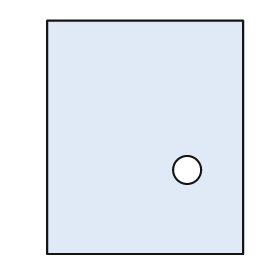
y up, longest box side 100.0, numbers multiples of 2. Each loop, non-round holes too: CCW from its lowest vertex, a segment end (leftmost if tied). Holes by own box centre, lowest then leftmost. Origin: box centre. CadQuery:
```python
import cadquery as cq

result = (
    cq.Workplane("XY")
    .moveTo(-42.0, -50.0)
    .lineTo(42.0, -50.0)
    .lineTo(42.0, 50.0)
    .lineTo(-42.0, 50.0)
    .close()
    .moveTo(18.0, -14.0)
    .circle(6.0)
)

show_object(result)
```